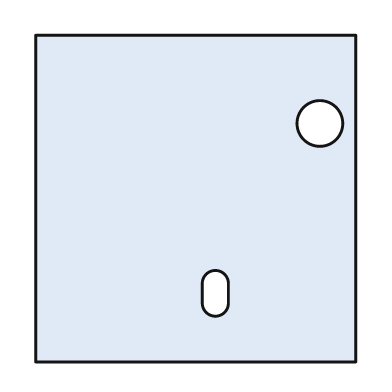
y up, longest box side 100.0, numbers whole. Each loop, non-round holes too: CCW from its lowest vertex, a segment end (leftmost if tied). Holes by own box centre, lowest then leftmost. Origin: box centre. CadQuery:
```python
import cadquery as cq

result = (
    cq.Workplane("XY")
    .moveTo(-49.0, -50.0)
    .lineTo(49.0, -50.0)
    .lineTo(49.0, 50.0)
    .lineTo(-49.0, 50.0)
    .close()
    .moveTo(2.0, -32.0)
    .threePointArc((6.0, -36.0), (10.0, -32.0))
    .lineTo(10.0, -26.0)
    .threePointArc((6.0, -22.0), (2.0, -26.0))
    .close()
    .moveTo(38.0, 23.0)
    .circle(7.0)
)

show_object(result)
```